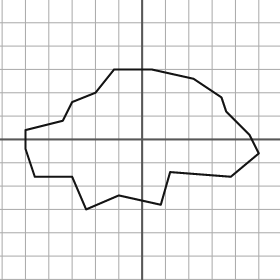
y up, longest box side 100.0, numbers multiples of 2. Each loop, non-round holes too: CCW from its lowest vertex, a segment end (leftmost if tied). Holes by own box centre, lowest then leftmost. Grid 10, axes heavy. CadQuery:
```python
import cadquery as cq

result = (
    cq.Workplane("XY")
    .moveTo(-24.0, -30.0)
    .lineTo(-10.0, -24.0)
    .lineTo(8.0, -28.0)
    .lineTo(12.0, -14.0)
    .lineTo(38.0, -16.0)
    .lineTo(50.0, -6.0)
    .lineTo(46.0, 2.0)
    .lineTo(36.0, 12.0)
    .lineTo(34.0, 18.0)
    .lineTo(22.0, 26.0)
    .lineTo(4.0, 30.0)
    .lineTo(-12.0, 30.0)
    .lineTo(-20.0, 20.0)
    .lineTo(-30.0, 16.0)
    .lineTo(-34.0, 8.0)
    .lineTo(-50.0, 4.0)
    .lineTo(-50.0, -4.0)
    .lineTo(-46.0, -16.0)
    .lineTo(-30.0, -16.0)
    .close()
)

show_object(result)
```